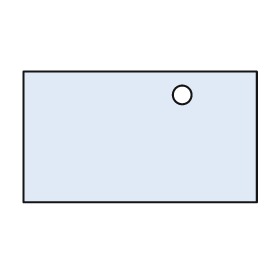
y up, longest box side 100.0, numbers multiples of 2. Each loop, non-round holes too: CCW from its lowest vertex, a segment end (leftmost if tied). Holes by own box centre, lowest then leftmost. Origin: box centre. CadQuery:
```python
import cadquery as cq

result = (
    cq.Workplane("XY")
    .moveTo(-50.0, -28.0)
    .lineTo(50.0, -28.0)
    .lineTo(50.0, 28.0)
    .lineTo(-50.0, 28.0)
    .close()
    .moveTo(18.0, 18.0)
    .circle(4.0)
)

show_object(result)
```